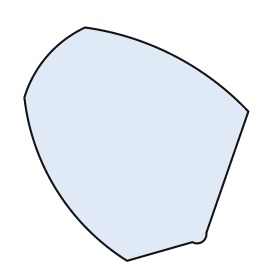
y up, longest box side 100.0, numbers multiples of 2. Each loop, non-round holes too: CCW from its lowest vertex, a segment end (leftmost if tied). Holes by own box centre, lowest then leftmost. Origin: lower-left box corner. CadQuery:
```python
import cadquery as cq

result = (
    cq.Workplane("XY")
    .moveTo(44.0, 0.0)
    .lineTo(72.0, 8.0)
    .threePointArc((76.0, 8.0), (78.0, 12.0))
    .lineTo(96.0, 64.0)
    .threePointArc((64.0, 88.0), (26.0, 100.0))
    .threePointArc((10.0, 88.0), (0.0, 70.0))
    .threePointArc((14.0, 30.0), (44.0, 0.0))
    .close()
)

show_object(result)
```